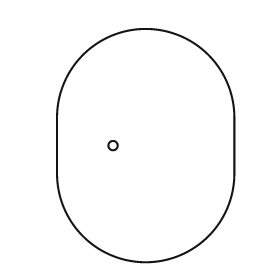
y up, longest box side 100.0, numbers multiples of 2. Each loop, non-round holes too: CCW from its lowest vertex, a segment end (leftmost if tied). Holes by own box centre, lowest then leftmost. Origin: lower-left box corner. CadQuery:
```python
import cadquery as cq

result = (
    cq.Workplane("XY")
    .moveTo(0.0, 38.0)
    .threePointArc((38.0, 0.0), (76.0, 38.0))
    .lineTo(76.0, 62.0)
    .threePointArc((38.0, 100.0), (0.0, 62.0))
    .close()
    .moveTo(24.0, 50.0)
    .circle(2.0)
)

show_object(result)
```